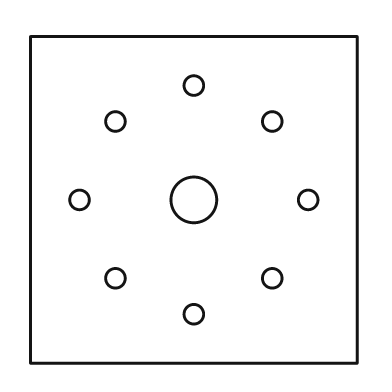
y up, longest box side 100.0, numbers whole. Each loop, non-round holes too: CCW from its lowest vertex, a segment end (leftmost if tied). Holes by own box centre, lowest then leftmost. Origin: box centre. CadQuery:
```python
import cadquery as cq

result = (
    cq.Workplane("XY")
    .moveTo(-50.0, -50.0)
    .lineTo(50.0, -50.0)
    .lineTo(50.0, 50.0)
    .lineTo(-50.0, 50.0)
    .close()
    .moveTo(0.0, -35.0)
    .circle(3.0)
    .moveTo(-24.0, -24.0)
    .circle(3.0)
    .moveTo(24.0, -24.0)
    .circle(3.0)
    .moveTo(-35.0, 0.0)
    .circle(3.0)
    .moveTo(0.0, 0.0)
    .circle(7.0)
    .moveTo(35.0, 0.0)
    .circle(3.0)
    .moveTo(-24.0, 24.0)
    .circle(3.0)
    .moveTo(24.0, 24.0)
    .circle(3.0)
    .moveTo(0.0, 35.0)
    .circle(3.0)
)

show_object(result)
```